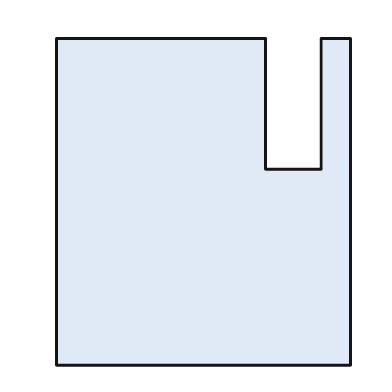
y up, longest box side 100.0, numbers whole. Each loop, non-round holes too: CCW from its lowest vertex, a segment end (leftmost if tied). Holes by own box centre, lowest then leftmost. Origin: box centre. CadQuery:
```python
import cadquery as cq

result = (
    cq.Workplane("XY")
    .moveTo(-45.0, -50.0)
    .lineTo(45.0, -50.0)
    .lineTo(45.0, 50.0)
    .lineTo(36.0, 50.0)
    .lineTo(36.0, 10.0)
    .lineTo(19.0, 10.0)
    .lineTo(19.0, 50.0)
    .lineTo(-45.0, 50.0)
    .close()
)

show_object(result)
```